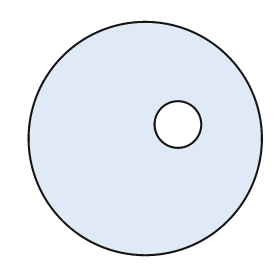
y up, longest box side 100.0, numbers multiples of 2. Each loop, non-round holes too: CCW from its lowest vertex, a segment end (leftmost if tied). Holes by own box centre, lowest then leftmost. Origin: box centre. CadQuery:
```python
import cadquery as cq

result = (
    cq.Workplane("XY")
    .moveTo(0.0, 0.0)
    .circle(50.0)
    .moveTo(14.0, 6.0)
    .circle(10.0)
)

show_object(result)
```